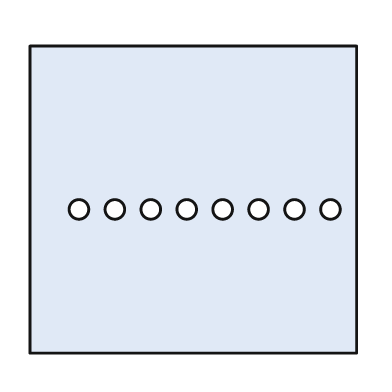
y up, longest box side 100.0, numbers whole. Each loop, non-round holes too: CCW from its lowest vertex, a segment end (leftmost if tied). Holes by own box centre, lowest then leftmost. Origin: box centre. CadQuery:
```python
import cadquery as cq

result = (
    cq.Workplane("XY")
    .moveTo(-50.0, -47.0)
    .lineTo(50.0, -47.0)
    .lineTo(50.0, 47.0)
    .lineTo(-50.0, 47.0)
    .close()
    .moveTo(-35.0, -3.0)
    .circle(3.0)
    .moveTo(-24.0, -3.0)
    .circle(3.0)
    .moveTo(-13.0, -3.0)
    .circle(3.0)
    .moveTo(-2.0, -3.0)
    .circle(3.0)
    .moveTo(9.0, -3.0)
    .circle(3.0)
    .moveTo(20.0, -3.0)
    .circle(3.0)
    .moveTo(31.0, -3.0)
    .circle(3.0)
    .moveTo(42.0, -3.0)
    .circle(3.0)
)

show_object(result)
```